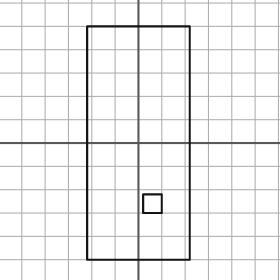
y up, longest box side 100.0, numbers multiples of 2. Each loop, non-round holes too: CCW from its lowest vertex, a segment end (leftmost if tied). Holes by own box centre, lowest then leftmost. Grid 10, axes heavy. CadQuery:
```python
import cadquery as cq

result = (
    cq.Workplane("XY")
    .moveTo(-22.0, -50.0)
    .lineTo(22.0, -50.0)
    .lineTo(22.0, 50.0)
    .lineTo(-22.0, 50.0)
    .close()
    .moveTo(2.0, -30.0)
    .lineTo(10.0, -30.0)
    .lineTo(10.0, -22.0)
    .lineTo(2.0, -22.0)
    .close()
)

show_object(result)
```